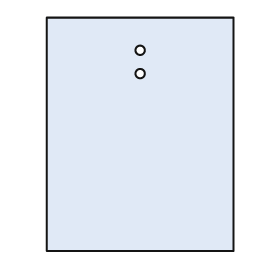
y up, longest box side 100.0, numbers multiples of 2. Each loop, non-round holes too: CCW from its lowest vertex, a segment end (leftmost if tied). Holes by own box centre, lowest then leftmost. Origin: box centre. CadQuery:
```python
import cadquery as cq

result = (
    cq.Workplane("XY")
    .moveTo(-40.0, -50.0)
    .lineTo(40.0, -50.0)
    .lineTo(40.0, 50.0)
    .lineTo(-40.0, 50.0)
    .close()
    .moveTo(0.0, 26.0)
    .circle(2.0)
    .moveTo(0.0, 36.0)
    .circle(2.0)
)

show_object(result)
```